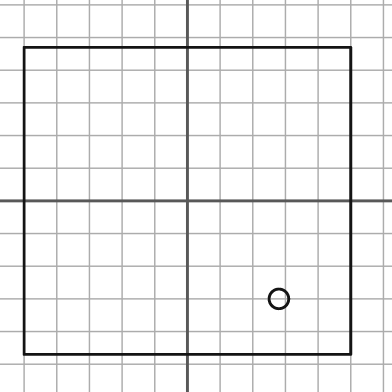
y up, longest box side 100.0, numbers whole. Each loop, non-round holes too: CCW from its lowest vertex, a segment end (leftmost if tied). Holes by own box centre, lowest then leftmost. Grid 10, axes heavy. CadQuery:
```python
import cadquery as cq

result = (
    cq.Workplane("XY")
    .moveTo(-50.0, -47.0)
    .lineTo(50.0, -47.0)
    .lineTo(50.0, 47.0)
    .lineTo(-50.0, 47.0)
    .close()
    .moveTo(28.0, -30.0)
    .circle(3.0)
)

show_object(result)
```